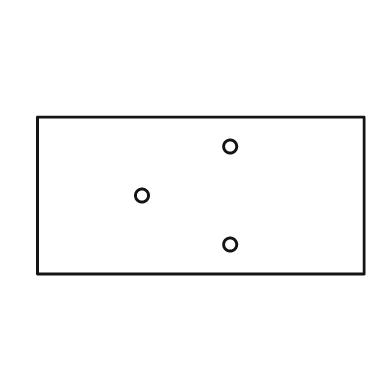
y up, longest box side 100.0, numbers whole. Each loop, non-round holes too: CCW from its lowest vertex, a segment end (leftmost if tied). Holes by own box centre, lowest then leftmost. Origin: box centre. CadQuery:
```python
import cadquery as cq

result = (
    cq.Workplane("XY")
    .moveTo(-50.0, -24.0)
    .lineTo(50.0, -24.0)
    .lineTo(50.0, 24.0)
    .lineTo(-50.0, 24.0)
    .close()
    .moveTo(9.0, -15.0)
    .circle(2.0)
    .moveTo(-18.0, 0.0)
    .circle(2.0)
    .moveTo(9.0, 15.0)
    .circle(2.0)
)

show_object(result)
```